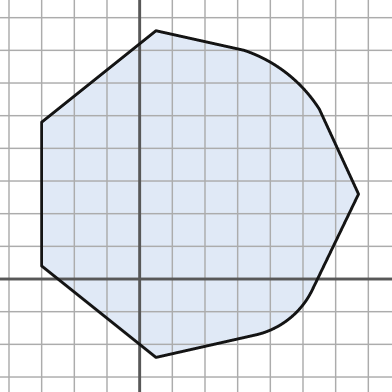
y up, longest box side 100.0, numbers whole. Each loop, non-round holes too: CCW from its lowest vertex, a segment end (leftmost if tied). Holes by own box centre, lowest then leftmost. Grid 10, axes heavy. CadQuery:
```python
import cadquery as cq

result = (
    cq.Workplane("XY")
    .moveTo(5.0, -24.0)
    .lineTo(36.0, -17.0)
    .threePointArc((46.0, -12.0), (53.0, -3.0))
    .lineTo(67.0, 26.0)
    .lineTo(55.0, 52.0)
    .threePointArc((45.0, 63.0), (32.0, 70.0))
    .lineTo(5.0, 76.0)
    .lineTo(-30.0, 48.0)
    .lineTo(-30.0, 4.0)
    .close()
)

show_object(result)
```